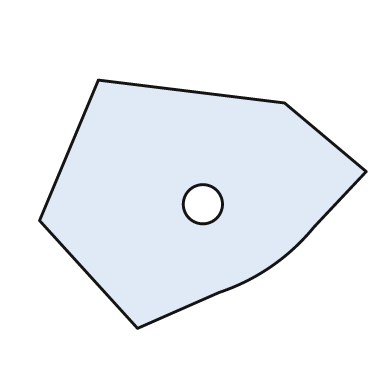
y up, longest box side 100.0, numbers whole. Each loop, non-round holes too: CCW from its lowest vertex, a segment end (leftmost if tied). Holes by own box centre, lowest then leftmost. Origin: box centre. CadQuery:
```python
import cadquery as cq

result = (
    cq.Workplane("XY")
    .moveTo(-20.0, -38.0)
    .lineTo(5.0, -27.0)
    .threePointArc((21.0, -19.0), (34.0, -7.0))
    .lineTo(50.0, 10.0)
    .lineTo(25.0, 31.0)
    .lineTo(-32.0, 38.0)
    .lineTo(-50.0, -5.0)
    .close()
    .moveTo(0.0, 0.0)
    .circle(6.0)
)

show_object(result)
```